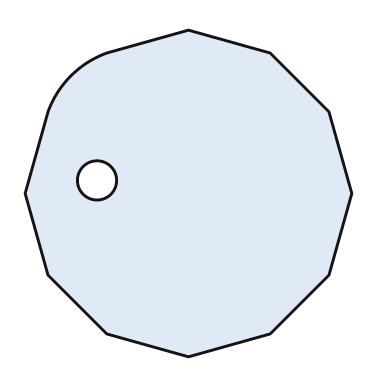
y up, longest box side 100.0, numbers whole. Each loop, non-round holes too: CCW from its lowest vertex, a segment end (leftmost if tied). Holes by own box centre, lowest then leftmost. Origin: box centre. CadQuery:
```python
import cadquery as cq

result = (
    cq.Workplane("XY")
    .moveTo(0.0, -50.0)
    .lineTo(25.0, -43.0)
    .lineTo(43.0, -25.0)
    .lineTo(50.0, 0.0)
    .lineTo(43.0, 25.0)
    .lineTo(25.0, 43.0)
    .lineTo(0.0, 50.0)
    .lineTo(-25.0, 43.0)
    .threePointArc((-36.0, 36.0), (-43.0, 25.0))
    .lineTo(-50.0, 0.0)
    .lineTo(-43.0, -25.0)
    .lineTo(-25.0, -43.0)
    .close()
    .moveTo(-28.0, 4.0)
    .circle(6.0)
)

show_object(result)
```